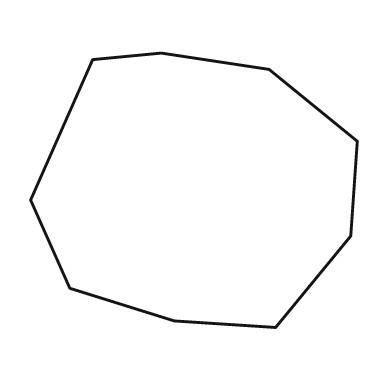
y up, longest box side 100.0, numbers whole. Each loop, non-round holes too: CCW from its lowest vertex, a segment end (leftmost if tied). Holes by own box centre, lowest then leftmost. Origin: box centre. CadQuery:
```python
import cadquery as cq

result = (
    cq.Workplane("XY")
    .moveTo(25.0, -42.0)
    .lineTo(48.0, -14.0)
    .lineTo(50.0, 15.0)
    .lineTo(23.0, 37.0)
    .lineTo(-10.0, 42.0)
    .lineTo(-31.0, 40.0)
    .lineTo(-50.0, -3.0)
    .lineTo(-38.0, -30.0)
    .lineTo(-6.0, -40.0)
    .close()
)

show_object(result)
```